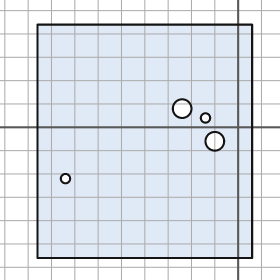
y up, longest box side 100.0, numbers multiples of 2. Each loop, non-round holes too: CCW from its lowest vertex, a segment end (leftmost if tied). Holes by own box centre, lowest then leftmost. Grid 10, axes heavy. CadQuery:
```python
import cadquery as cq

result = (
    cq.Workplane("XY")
    .moveTo(-86.0, -56.0)
    .lineTo(6.0, -56.0)
    .lineTo(6.0, 44.0)
    .lineTo(-86.0, 44.0)
    .close()
    .moveTo(-74.0, -22.0)
    .circle(2.0)
    .moveTo(-10.0, -6.0)
    .circle(4.0)
    .moveTo(-14.0, 4.0)
    .circle(2.0)
    .moveTo(-24.0, 8.0)
    .circle(4.0)
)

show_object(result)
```